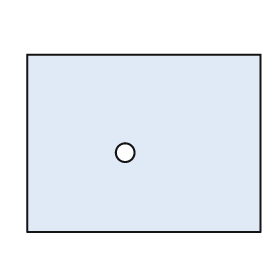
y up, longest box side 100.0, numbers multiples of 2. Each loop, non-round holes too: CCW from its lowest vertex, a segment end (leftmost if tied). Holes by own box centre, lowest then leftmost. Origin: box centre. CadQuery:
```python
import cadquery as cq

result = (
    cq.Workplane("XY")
    .moveTo(-50.0, -38.0)
    .lineTo(50.0, -38.0)
    .lineTo(50.0, 38.0)
    .lineTo(-50.0, 38.0)
    .close()
    .moveTo(-8.0, -4.0)
    .circle(4.0)
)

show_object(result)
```